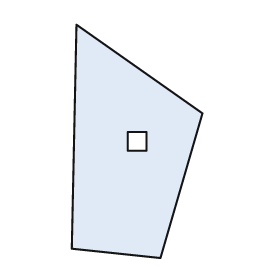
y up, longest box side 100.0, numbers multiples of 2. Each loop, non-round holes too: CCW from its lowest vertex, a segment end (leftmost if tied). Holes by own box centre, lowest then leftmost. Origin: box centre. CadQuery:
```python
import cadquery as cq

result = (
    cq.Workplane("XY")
    .moveTo(10.0, -50.0)
    .lineTo(28.0, 12.0)
    .lineTo(-26.0, 50.0)
    .lineTo(-28.0, -46.0)
    .close()
    .moveTo(-4.0, -4.0)
    .lineTo(4.0, -4.0)
    .lineTo(4.0, 4.0)
    .lineTo(-4.0, 4.0)
    .close()
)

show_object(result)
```